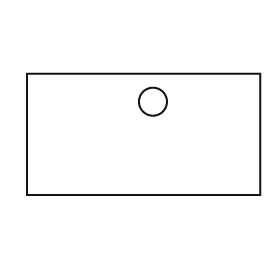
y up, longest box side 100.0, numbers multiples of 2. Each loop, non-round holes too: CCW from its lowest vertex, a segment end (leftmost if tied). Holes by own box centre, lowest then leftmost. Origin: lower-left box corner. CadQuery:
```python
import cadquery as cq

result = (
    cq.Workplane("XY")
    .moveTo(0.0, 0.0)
    .lineTo(100.0, 0.0)
    .lineTo(100.0, 52.0)
    .lineTo(0.0, 52.0)
    .close()
    .moveTo(54.0, 40.0)
    .circle(6.0)
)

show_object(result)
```